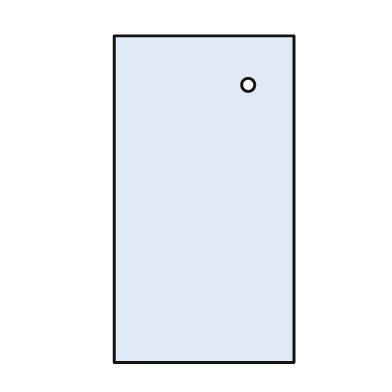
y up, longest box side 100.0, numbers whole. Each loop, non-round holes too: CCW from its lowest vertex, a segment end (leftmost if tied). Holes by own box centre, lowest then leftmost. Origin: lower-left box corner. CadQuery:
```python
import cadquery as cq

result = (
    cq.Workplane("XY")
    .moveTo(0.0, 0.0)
    .lineTo(55.0, 0.0)
    .lineTo(55.0, 100.0)
    .lineTo(0.0, 100.0)
    .close()
    .moveTo(41.0, 85.0)
    .circle(2.0)
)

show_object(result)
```